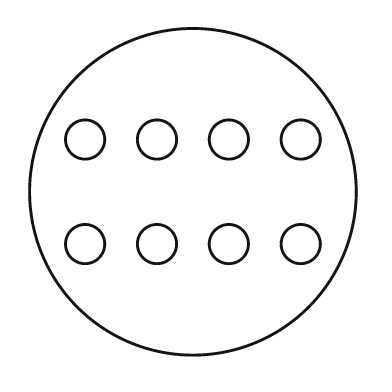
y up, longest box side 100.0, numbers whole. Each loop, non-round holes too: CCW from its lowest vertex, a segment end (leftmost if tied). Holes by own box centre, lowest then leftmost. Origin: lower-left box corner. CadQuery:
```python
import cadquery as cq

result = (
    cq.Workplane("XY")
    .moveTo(50.0, 50.0)
    .circle(50.0)
    .moveTo(17.0, 34.0)
    .circle(6.0)
    .moveTo(39.0, 34.0)
    .circle(6.0)
    .moveTo(61.0, 34.0)
    .circle(6.0)
    .moveTo(83.0, 34.0)
    .circle(6.0)
    .moveTo(17.0, 66.0)
    .circle(6.0)
    .moveTo(39.0, 66.0)
    .circle(6.0)
    .moveTo(61.0, 66.0)
    .circle(6.0)
    .moveTo(83.0, 66.0)
    .circle(6.0)
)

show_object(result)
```